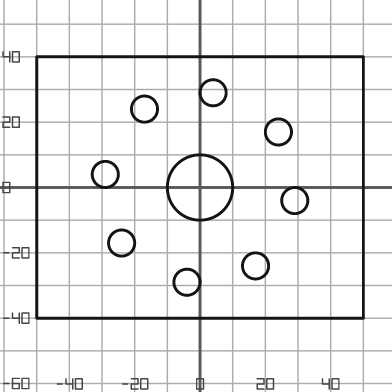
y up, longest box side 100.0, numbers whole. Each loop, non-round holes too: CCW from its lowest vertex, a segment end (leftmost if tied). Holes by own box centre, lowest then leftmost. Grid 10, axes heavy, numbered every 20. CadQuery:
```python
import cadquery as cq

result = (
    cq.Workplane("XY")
    .moveTo(-50.0, -40.0)
    .lineTo(50.0, -40.0)
    .lineTo(50.0, 40.0)
    .lineTo(-50.0, 40.0)
    .close()
    .moveTo(-4.0, -29.0)
    .circle(4.0)
    .moveTo(17.0, -24.0)
    .circle(4.0)
    .moveTo(-24.0, -17.0)
    .circle(4.0)
    .moveTo(29.0, -4.0)
    .circle(4.0)
    .moveTo(0.0, 0.0)
    .circle(10.0)
    .moveTo(-29.0, 4.0)
    .circle(4.0)
    .moveTo(24.0, 17.0)
    .circle(4.0)
    .moveTo(-17.0, 24.0)
    .circle(4.0)
    .moveTo(4.0, 29.0)
    .circle(4.0)
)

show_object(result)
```